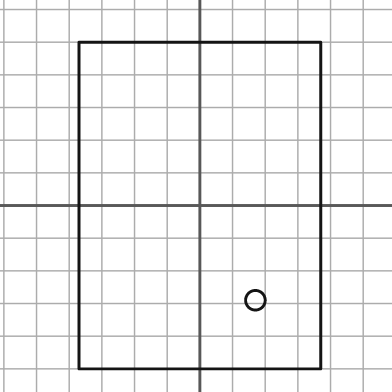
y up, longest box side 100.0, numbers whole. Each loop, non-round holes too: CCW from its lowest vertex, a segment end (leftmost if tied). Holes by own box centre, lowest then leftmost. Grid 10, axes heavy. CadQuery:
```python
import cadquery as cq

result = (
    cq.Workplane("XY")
    .moveTo(-37.0, -50.0)
    .lineTo(37.0, -50.0)
    .lineTo(37.0, 50.0)
    .lineTo(-37.0, 50.0)
    .close()
    .moveTo(17.0, -29.0)
    .circle(3.0)
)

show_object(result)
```